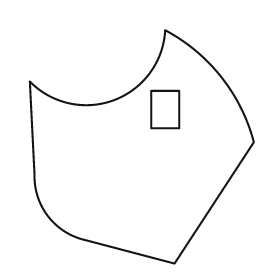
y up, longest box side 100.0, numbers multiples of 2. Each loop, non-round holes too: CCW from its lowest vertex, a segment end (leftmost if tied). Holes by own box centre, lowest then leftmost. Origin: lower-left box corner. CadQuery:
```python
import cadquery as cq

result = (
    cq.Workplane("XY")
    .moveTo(62.0, 0.0)
    .lineTo(96.0, 52.0)
    .threePointArc((82.0, 80.0), (58.0, 100.0))
    .threePointArc((36.0, 70.0), (0.0, 78.0))
    .lineTo(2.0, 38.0)
    .threePointArc((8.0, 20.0), (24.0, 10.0))
    .close()
    .moveTo(52.0, 58.0)
    .lineTo(64.0, 58.0)
    .lineTo(64.0, 74.0)
    .lineTo(52.0, 74.0)
    .close()
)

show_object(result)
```